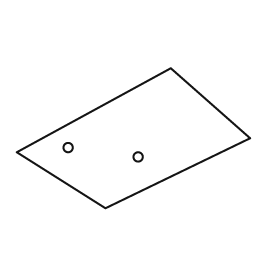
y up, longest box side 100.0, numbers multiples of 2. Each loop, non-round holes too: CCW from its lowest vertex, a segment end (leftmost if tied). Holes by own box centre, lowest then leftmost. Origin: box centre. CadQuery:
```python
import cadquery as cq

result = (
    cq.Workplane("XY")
    .moveTo(-12.0, -30.0)
    .lineTo(50.0, 0.0)
    .lineTo(16.0, 30.0)
    .lineTo(-50.0, -6.0)
    .close()
    .moveTo(2.0, -8.0)
    .circle(2.0)
    .moveTo(-28.0, -4.0)
    .circle(2.0)
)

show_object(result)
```